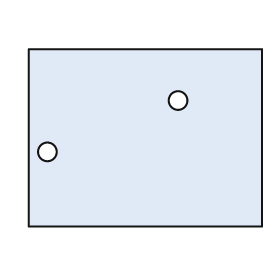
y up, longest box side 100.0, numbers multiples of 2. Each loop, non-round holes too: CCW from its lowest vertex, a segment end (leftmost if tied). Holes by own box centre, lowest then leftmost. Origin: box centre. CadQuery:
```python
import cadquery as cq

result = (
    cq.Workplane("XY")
    .moveTo(-50.0, -38.0)
    .lineTo(50.0, -38.0)
    .lineTo(50.0, 38.0)
    .lineTo(-50.0, 38.0)
    .close()
    .moveTo(-42.0, -6.0)
    .circle(4.0)
    .moveTo(14.0, 16.0)
    .circle(4.0)
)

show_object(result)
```